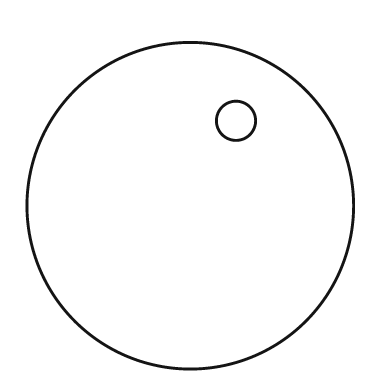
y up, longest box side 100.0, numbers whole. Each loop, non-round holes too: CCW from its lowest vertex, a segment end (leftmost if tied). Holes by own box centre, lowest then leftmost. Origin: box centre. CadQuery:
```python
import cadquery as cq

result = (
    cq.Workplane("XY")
    .moveTo(0.0, 0.0)
    .circle(50.0)
    .moveTo(14.0, 26.0)
    .circle(6.0)
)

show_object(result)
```